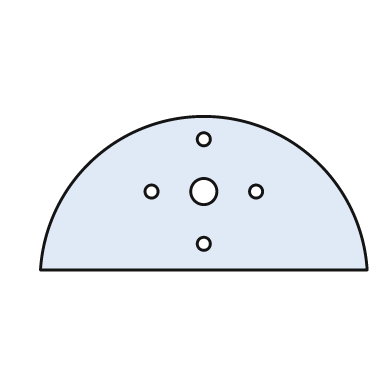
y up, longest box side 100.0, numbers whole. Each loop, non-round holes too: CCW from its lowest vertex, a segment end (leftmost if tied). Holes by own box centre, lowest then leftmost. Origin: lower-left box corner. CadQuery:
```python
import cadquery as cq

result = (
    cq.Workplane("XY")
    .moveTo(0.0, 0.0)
    .lineTo(100.0, 0.0)
    .threePointArc((50.0, 47.0), (0.0, 0.0))
    .close()
    .moveTo(50.0, 8.0)
    .circle(2.0)
    .moveTo(34.0, 24.0)
    .circle(2.0)
    .moveTo(50.0, 24.0)
    .circle(4.0)
    .moveTo(66.0, 24.0)
    .circle(2.0)
    .moveTo(50.0, 40.0)
    .circle(2.0)
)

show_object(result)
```